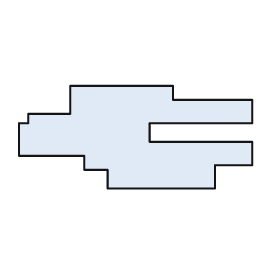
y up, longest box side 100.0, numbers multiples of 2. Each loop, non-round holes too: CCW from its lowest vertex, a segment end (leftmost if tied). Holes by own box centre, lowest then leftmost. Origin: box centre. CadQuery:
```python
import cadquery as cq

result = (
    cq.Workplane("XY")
    .moveTo(-12.0, -22.0)
    .lineTo(34.0, -22.0)
    .lineTo(34.0, -12.0)
    .lineTo(50.0, -12.0)
    .lineTo(50.0, -2.0)
    .lineTo(6.0, -2.0)
    .lineTo(6.0, 6.0)
    .lineTo(50.0, 6.0)
    .lineTo(50.0, 16.0)
    .lineTo(16.0, 16.0)
    .lineTo(16.0, 22.0)
    .lineTo(-28.0, 22.0)
    .lineTo(-28.0, 10.0)
    .lineTo(-46.0, 10.0)
    .lineTo(-46.0, 6.0)
    .lineTo(-50.0, 6.0)
    .lineTo(-50.0, -8.0)
    .lineTo(-22.0, -8.0)
    .lineTo(-22.0, -14.0)
    .lineTo(-12.0, -14.0)
    .close()
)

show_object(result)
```